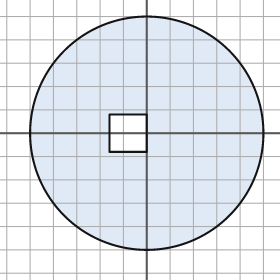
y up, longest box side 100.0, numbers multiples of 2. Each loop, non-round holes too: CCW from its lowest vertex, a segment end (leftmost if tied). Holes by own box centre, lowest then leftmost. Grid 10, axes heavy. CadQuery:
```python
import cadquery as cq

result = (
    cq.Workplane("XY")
    .moveTo(0.0, 0.0)
    .circle(50.0)
    .moveTo(-16.0, -8.0)
    .lineTo(0.0, -8.0)
    .lineTo(0.0, 8.0)
    .lineTo(-16.0, 8.0)
    .close()
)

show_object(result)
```